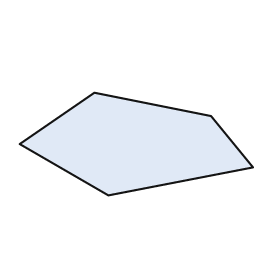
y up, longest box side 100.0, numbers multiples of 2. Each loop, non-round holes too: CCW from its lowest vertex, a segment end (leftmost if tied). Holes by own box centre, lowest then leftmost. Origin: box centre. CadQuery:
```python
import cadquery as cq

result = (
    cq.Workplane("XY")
    .moveTo(-12.0, -22.0)
    .lineTo(50.0, -10.0)
    .lineTo(32.0, 12.0)
    .lineTo(-18.0, 22.0)
    .lineTo(-50.0, 0.0)
    .close()
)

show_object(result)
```